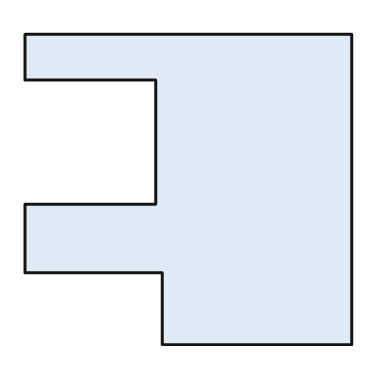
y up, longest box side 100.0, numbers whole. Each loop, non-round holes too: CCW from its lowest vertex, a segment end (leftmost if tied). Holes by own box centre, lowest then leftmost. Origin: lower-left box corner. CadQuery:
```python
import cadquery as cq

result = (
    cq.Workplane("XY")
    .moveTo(42.0, 0.0)
    .lineTo(100.0, 0.0)
    .lineTo(100.0, 95.0)
    .lineTo(0.0, 95.0)
    .lineTo(0.0, 81.0)
    .lineTo(40.0, 81.0)
    .lineTo(40.0, 43.0)
    .lineTo(0.0, 43.0)
    .lineTo(0.0, 22.0)
    .lineTo(42.0, 22.0)
    .close()
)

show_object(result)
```